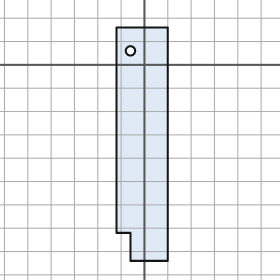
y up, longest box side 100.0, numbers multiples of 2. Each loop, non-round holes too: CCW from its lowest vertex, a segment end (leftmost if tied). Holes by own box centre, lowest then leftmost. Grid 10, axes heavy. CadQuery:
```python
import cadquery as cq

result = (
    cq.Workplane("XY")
    .moveTo(-6.0, -84.0)
    .lineTo(10.0, -84.0)
    .lineTo(10.0, 16.0)
    .lineTo(-12.0, 16.0)
    .lineTo(-12.0, -72.0)
    .lineTo(-6.0, -72.0)
    .close()
    .moveTo(-6.0, 6.0)
    .circle(2.0)
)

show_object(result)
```